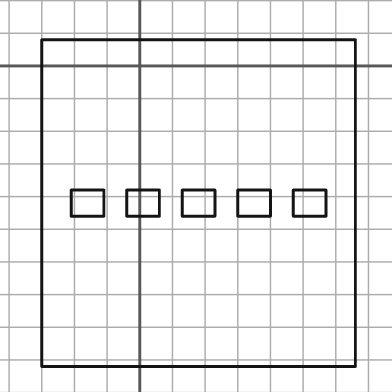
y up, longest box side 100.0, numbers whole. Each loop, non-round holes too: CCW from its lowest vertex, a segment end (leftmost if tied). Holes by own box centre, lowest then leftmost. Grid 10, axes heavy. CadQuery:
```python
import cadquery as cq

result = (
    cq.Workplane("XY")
    .moveTo(-30.0, -92.0)
    .lineTo(66.0, -92.0)
    .lineTo(66.0, 8.0)
    .lineTo(-30.0, 8.0)
    .close()
    .moveTo(-21.0, -46.0)
    .lineTo(-11.0, -46.0)
    .lineTo(-11.0, -38.0)
    .lineTo(-21.0, -38.0)
    .close()
    .moveTo(-4.0, -46.0)
    .lineTo(6.0, -46.0)
    .lineTo(6.0, -38.0)
    .lineTo(-4.0, -38.0)
    .close()
    .moveTo(13.0, -46.0)
    .lineTo(23.0, -46.0)
    .lineTo(23.0, -38.0)
    .lineTo(13.0, -38.0)
    .close()
    .moveTo(30.0, -46.0)
    .lineTo(40.0, -46.0)
    .lineTo(40.0, -38.0)
    .lineTo(30.0, -38.0)
    .close()
    .moveTo(47.0, -46.0)
    .lineTo(57.0, -46.0)
    .lineTo(57.0, -38.0)
    .lineTo(47.0, -38.0)
    .close()
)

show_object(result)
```